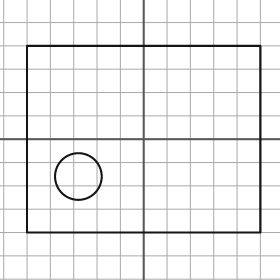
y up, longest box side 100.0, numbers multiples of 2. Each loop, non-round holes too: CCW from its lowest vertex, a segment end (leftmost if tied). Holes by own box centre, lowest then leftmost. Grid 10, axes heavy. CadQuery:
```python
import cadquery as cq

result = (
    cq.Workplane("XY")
    .moveTo(-50.0, -40.0)
    .lineTo(50.0, -40.0)
    .lineTo(50.0, 40.0)
    .lineTo(-50.0, 40.0)
    .close()
    .moveTo(-28.0, -16.0)
    .circle(10.0)
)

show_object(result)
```